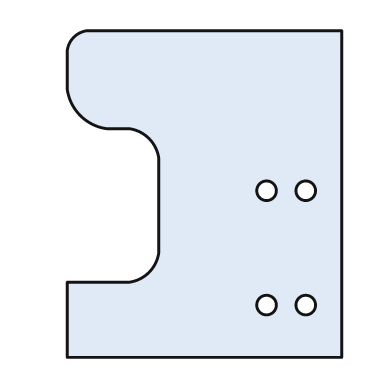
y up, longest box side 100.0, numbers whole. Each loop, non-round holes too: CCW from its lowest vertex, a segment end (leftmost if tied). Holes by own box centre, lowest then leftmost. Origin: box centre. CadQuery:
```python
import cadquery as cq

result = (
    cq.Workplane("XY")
    .moveTo(-42.0, -50.0)
    .lineTo(42.0, -50.0)
    .lineTo(42.0, 50.0)
    .lineTo(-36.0, 50.0)
    .threePointArc((-40.0, 48.0), (-42.0, 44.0))
    .lineTo(-42.0, 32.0)
    .threePointArc((-38.0, 24.0), (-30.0, 20.0))
    .lineTo(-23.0, 20.0)
    .threePointArc((-17.0, 17.0), (-14.0, 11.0))
    .lineTo(-14.0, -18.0)
    .threePointArc((-17.0, -24.0), (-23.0, -27.0))
    .lineTo(-42.0, -27.0)
    .close()
    .moveTo(19.0, -34.0)
    .circle(3.0)
    .moveTo(31.0, -34.0)
    .circle(3.0)
    .moveTo(19.0, 1.0)
    .circle(3.0)
    .moveTo(31.0, 1.0)
    .circle(3.0)
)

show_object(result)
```